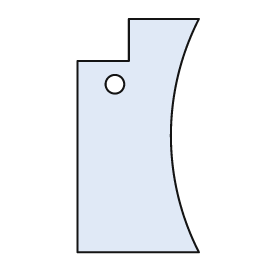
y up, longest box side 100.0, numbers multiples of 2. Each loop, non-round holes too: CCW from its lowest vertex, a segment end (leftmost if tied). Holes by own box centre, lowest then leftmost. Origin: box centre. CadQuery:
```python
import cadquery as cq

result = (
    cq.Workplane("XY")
    .moveTo(-26.0, -50.0)
    .lineTo(26.0, -50.0)
    .threePointArc((14.0, 0.0), (26.0, 50.0))
    .lineTo(-4.0, 50.0)
    .lineTo(-4.0, 32.0)
    .lineTo(-26.0, 32.0)
    .close()
    .moveTo(-10.0, 22.0)
    .circle(4.0)
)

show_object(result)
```